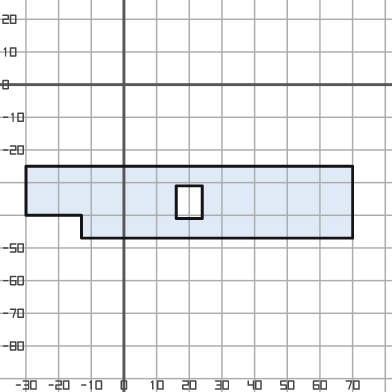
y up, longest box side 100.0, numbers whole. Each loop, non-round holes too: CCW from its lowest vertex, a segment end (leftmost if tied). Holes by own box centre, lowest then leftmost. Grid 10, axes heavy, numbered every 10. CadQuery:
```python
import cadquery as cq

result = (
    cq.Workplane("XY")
    .moveTo(-13.0, -47.0)
    .lineTo(70.0, -47.0)
    .lineTo(70.0, -25.0)
    .lineTo(-30.0, -25.0)
    .lineTo(-30.0, -40.0)
    .lineTo(-13.0, -40.0)
    .close()
    .moveTo(16.0, -41.0)
    .lineTo(24.0, -41.0)
    .lineTo(24.0, -31.0)
    .lineTo(16.0, -31.0)
    .close()
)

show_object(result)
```